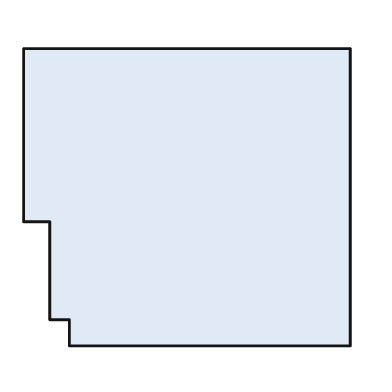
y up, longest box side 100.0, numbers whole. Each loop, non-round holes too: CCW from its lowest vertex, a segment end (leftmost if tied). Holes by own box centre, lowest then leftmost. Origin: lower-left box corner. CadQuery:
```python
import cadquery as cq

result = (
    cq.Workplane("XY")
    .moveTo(14.0, 0.0)
    .lineTo(100.0, 0.0)
    .lineTo(100.0, 91.0)
    .lineTo(0.0, 91.0)
    .lineTo(0.0, 38.0)
    .lineTo(8.0, 38.0)
    .lineTo(8.0, 8.0)
    .lineTo(14.0, 8.0)
    .close()
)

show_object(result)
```